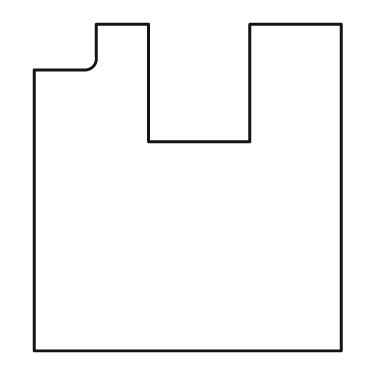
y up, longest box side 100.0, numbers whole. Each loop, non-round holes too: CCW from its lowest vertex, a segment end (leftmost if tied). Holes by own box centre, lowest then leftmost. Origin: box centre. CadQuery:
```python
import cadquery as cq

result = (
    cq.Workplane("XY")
    .moveTo(-47.0, -50.0)
    .lineTo(47.0, -50.0)
    .lineTo(47.0, 50.0)
    .lineTo(19.0, 50.0)
    .lineTo(19.0, 14.0)
    .lineTo(-12.0, 14.0)
    .lineTo(-12.0, 50.0)
    .lineTo(-28.0, 50.0)
    .lineTo(-28.0, 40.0)
    .threePointArc((-29.0, 37.0), (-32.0, 36.0))
    .lineTo(-47.0, 36.0)
    .close()
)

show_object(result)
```